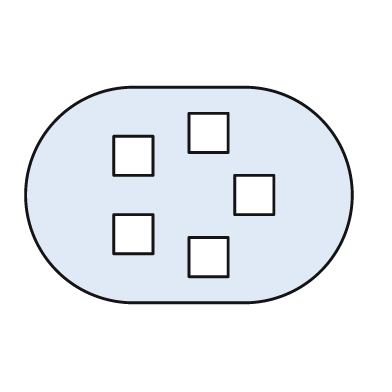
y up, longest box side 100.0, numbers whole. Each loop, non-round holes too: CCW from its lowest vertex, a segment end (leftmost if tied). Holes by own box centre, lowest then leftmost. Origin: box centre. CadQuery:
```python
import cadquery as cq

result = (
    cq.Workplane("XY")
    .moveTo(-17.0, -33.0)
    .lineTo(17.0, -33.0)
    .threePointArc((50.0, 0.0), (17.0, 33.0))
    .lineTo(-17.0, 33.0)
    .threePointArc((-50.0, 0.0), (-17.0, -33.0))
    .close()
    .moveTo(0.0, -25.0)
    .lineTo(12.0, -25.0)
    .lineTo(12.0, -13.0)
    .lineTo(0.0, -13.0)
    .close()
    .moveTo(-23.0, -18.0)
    .lineTo(-11.0, -18.0)
    .lineTo(-11.0, -6.0)
    .lineTo(-23.0, -6.0)
    .close()
    .moveTo(14.0, -6.0)
    .lineTo(26.0, -6.0)
    .lineTo(26.0, 6.0)
    .lineTo(14.0, 6.0)
    .close()
    .moveTo(-23.0, 6.0)
    .lineTo(-11.0, 6.0)
    .lineTo(-11.0, 18.0)
    .lineTo(-23.0, 18.0)
    .close()
    .moveTo(0.0, 13.0)
    .lineTo(12.0, 13.0)
    .lineTo(12.0, 25.0)
    .lineTo(0.0, 25.0)
    .close()
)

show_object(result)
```